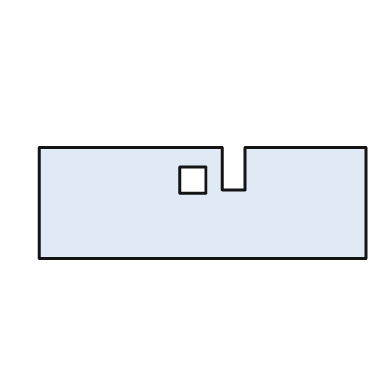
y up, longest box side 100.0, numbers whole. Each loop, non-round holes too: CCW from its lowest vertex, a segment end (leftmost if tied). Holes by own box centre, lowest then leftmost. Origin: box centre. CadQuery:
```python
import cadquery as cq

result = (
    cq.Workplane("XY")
    .moveTo(-50.0, -17.0)
    .lineTo(50.0, -17.0)
    .lineTo(50.0, 17.0)
    .lineTo(13.0, 17.0)
    .lineTo(13.0, 4.0)
    .lineTo(6.0, 4.0)
    .lineTo(6.0, 17.0)
    .lineTo(-50.0, 17.0)
    .close()
    .moveTo(-7.0, 3.0)
    .lineTo(1.0, 3.0)
    .lineTo(1.0, 11.0)
    .lineTo(-7.0, 11.0)
    .close()
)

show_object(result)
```